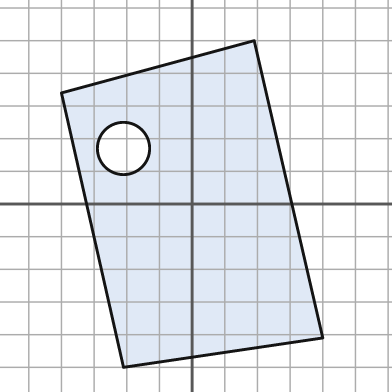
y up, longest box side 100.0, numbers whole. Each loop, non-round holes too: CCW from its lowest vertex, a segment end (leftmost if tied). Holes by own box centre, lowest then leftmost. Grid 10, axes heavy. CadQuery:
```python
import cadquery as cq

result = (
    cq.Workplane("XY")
    .moveTo(-21.0, -50.0)
    .lineTo(40.0, -41.0)
    .lineTo(19.0, 50.0)
    .lineTo(-40.0, 34.0)
    .close()
    .moveTo(-21.0, 17.0)
    .circle(8.0)
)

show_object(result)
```